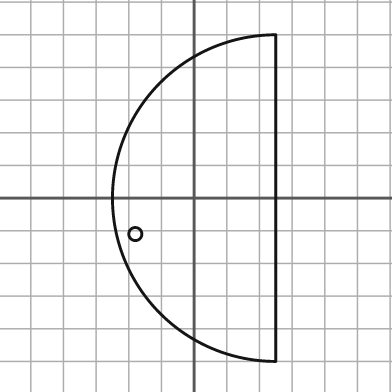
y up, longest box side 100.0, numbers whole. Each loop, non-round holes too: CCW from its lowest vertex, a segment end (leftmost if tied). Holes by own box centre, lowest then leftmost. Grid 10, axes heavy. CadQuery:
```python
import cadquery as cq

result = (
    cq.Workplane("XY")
    .moveTo(25.0, -50.0)
    .lineTo(25.0, 50.0)
    .threePointArc((-25.0, 0.0), (25.0, -50.0))
    .close()
    .moveTo(-18.0, -11.0)
    .circle(2.0)
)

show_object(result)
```